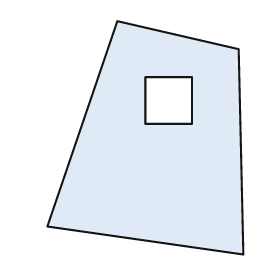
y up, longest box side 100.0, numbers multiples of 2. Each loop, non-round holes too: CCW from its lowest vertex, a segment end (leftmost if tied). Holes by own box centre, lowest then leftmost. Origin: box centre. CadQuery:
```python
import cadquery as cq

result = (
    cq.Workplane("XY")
    .moveTo(42.0, -50.0)
    .lineTo(40.0, 38.0)
    .lineTo(-12.0, 50.0)
    .lineTo(-42.0, -38.0)
    .close()
    .moveTo(0.0, 6.0)
    .lineTo(20.0, 6.0)
    .lineTo(20.0, 26.0)
    .lineTo(0.0, 26.0)
    .close()
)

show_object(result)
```